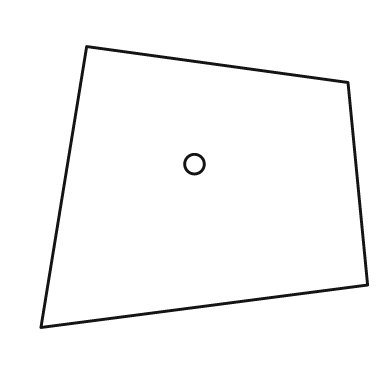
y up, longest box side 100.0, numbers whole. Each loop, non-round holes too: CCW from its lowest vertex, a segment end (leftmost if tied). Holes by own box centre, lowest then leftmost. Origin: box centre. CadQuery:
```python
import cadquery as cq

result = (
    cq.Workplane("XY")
    .moveTo(-50.0, -43.0)
    .lineTo(50.0, -30.0)
    .lineTo(44.0, 32.0)
    .lineTo(-36.0, 43.0)
    .close()
    .moveTo(-3.0, 7.0)
    .circle(3.0)
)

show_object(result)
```